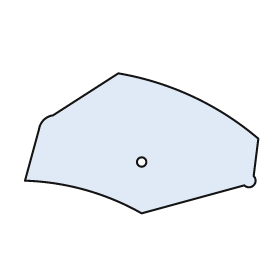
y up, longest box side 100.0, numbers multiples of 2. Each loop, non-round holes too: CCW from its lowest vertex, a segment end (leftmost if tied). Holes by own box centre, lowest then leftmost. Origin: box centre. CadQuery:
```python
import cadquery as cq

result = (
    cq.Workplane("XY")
    .moveTo(0.0, -30.0)
    .lineTo(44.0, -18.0)
    .threePointArc((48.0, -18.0), (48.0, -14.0))
    .lineTo(50.0, 2.0)
    .threePointArc((22.0, 20.0), (-10.0, 30.0))
    .lineTo(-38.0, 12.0)
    .threePointArc((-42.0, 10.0), (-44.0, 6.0))
    .lineTo(-50.0, -16.0)
    .threePointArc((-24.0, -20.0), (0.0, -30.0))
    .close()
    .moveTo(0.0, -8.0)
    .circle(2.0)
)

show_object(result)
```